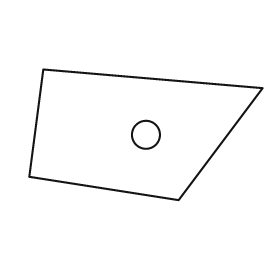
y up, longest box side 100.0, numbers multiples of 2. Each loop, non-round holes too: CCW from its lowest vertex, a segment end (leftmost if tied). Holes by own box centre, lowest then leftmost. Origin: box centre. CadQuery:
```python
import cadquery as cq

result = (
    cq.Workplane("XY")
    .moveTo(14.0, -28.0)
    .lineTo(50.0, 20.0)
    .lineTo(-44.0, 28.0)
    .lineTo(-50.0, -18.0)
    .close()
    .moveTo(0.0, 0.0)
    .circle(6.0)
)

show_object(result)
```